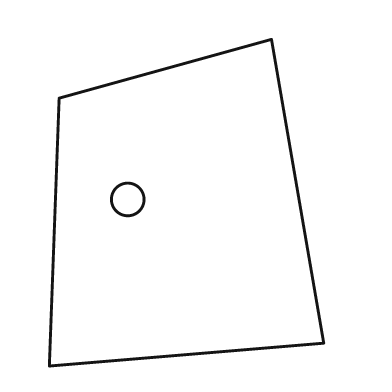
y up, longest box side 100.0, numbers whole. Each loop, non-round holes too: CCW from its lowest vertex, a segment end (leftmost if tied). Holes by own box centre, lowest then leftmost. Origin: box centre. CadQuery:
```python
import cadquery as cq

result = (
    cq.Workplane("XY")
    .moveTo(-42.0, -50.0)
    .lineTo(42.0, -43.0)
    .lineTo(26.0, 50.0)
    .lineTo(-39.0, 32.0)
    .close()
    .moveTo(-18.0, 1.0)
    .circle(5.0)
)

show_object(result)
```